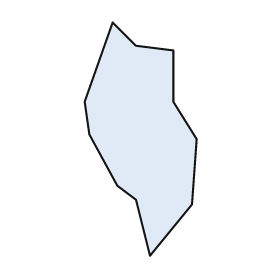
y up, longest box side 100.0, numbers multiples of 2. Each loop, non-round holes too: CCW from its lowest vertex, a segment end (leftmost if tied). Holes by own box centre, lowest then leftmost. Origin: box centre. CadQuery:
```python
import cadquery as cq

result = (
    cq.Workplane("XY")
    .moveTo(4.0, -50.0)
    .lineTo(22.0, -28.0)
    .lineTo(24.0, 0.0)
    .lineTo(14.0, 16.0)
    .lineTo(14.0, 38.0)
    .lineTo(-2.0, 40.0)
    .lineTo(-12.0, 50.0)
    .lineTo(-24.0, 16.0)
    .lineTo(-22.0, 2.0)
    .lineTo(-10.0, -20.0)
    .lineTo(-2.0, -26.0)
    .close()
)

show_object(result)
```